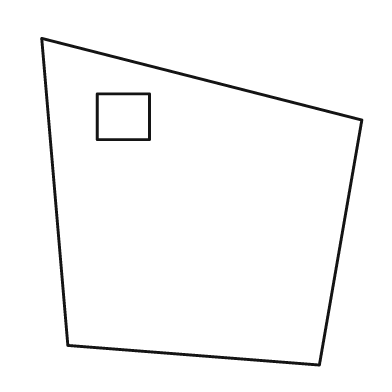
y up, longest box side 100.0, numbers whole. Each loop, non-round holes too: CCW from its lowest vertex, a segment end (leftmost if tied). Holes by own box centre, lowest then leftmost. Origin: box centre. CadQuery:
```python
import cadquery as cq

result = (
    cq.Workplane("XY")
    .moveTo(36.0, -50.0)
    .lineTo(49.0, 25.0)
    .lineTo(-49.0, 50.0)
    .lineTo(-41.0, -44.0)
    .close()
    .moveTo(-32.0, 19.0)
    .lineTo(-16.0, 19.0)
    .lineTo(-16.0, 33.0)
    .lineTo(-32.0, 33.0)
    .close()
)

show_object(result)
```